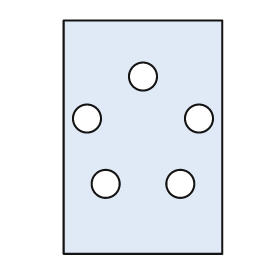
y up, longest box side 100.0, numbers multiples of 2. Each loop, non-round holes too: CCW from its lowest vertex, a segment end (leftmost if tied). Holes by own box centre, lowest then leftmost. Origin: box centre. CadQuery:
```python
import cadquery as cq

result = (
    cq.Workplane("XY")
    .moveTo(-34.0, -50.0)
    .lineTo(34.0, -50.0)
    .lineTo(34.0, 50.0)
    .lineTo(-34.0, 50.0)
    .close()
    .moveTo(-16.0, -20.0)
    .circle(6.0)
    .moveTo(16.0, -20.0)
    .circle(6.0)
    .moveTo(-24.0, 8.0)
    .circle(6.0)
    .moveTo(24.0, 8.0)
    .circle(6.0)
    .moveTo(0.0, 26.0)
    .circle(6.0)
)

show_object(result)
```